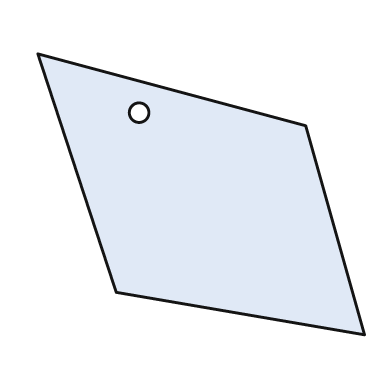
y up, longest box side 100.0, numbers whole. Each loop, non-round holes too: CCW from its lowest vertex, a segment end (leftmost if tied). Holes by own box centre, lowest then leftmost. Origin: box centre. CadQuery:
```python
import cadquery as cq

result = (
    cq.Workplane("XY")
    .moveTo(50.0, -43.0)
    .lineTo(32.0, 21.0)
    .lineTo(-50.0, 43.0)
    .lineTo(-26.0, -30.0)
    .close()
    .moveTo(-19.0, 25.0)
    .circle(3.0)
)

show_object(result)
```